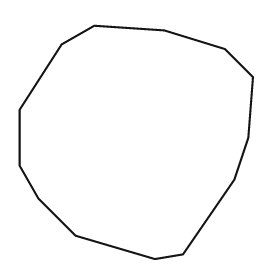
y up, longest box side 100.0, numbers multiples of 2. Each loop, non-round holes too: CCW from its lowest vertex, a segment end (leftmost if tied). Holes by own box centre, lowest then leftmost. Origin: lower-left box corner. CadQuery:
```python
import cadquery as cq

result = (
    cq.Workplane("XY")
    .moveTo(58.0, 0.0)
    .lineTo(70.0, 2.0)
    .lineTo(92.0, 34.0)
    .lineTo(98.0, 52.0)
    .lineTo(100.0, 78.0)
    .lineTo(88.0, 90.0)
    .lineTo(62.0, 98.0)
    .lineTo(32.0, 100.0)
    .lineTo(18.0, 92.0)
    .lineTo(0.0, 64.0)
    .lineTo(0.0, 40.0)
    .lineTo(8.0, 26.0)
    .lineTo(24.0, 10.0)
    .close()
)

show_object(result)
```